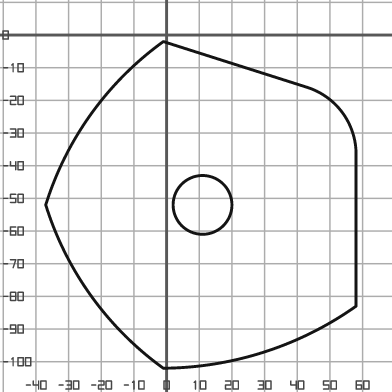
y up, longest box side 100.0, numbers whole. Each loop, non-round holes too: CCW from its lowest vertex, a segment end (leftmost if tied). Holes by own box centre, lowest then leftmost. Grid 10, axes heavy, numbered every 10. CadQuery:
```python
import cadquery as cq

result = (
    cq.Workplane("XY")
    .moveTo(-1.0, -102.0)
    .threePointArc((30.0, -97.0), (58.0, -83.0))
    .lineTo(58.0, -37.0)
    .threePointArc((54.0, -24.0), (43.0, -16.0))
    .lineTo(-1.0, -2.0)
    .threePointArc((-23.0, -24.0), (-37.0, -52.0))
    .threePointArc((-23.0, -80.0), (-1.0, -102.0))
    .close()
    .moveTo(11.0, -52.0)
    .circle(9.0)
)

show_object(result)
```